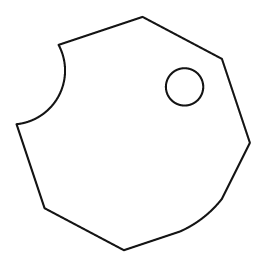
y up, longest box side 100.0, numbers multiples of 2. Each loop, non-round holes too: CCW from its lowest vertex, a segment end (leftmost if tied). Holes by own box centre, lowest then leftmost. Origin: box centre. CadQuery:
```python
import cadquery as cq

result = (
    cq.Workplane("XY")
    .moveTo(-4.0, -50.0)
    .lineTo(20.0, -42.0)
    .threePointArc((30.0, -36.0), (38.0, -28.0))
    .lineTo(50.0, -4.0)
    .lineTo(38.0, 32.0)
    .lineTo(4.0, 50.0)
    .lineTo(-32.0, 38.0)
    .threePointArc((-32.0, 16.0), (-50.0, 4.0))
    .lineTo(-38.0, -32.0)
    .close()
    .moveTo(22.0, 20.0)
    .circle(8.0)
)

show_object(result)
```